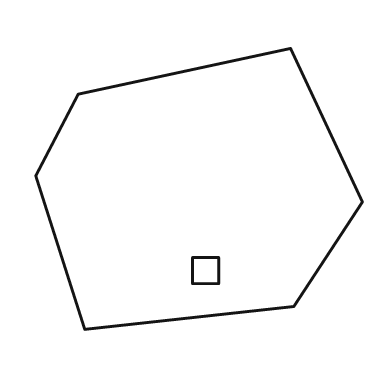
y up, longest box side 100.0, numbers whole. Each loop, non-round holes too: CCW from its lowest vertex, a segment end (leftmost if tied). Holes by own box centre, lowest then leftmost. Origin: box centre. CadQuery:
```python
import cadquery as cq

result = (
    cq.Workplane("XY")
    .moveTo(-35.0, -43.0)
    .lineTo(29.0, -36.0)
    .lineTo(50.0, -4.0)
    .lineTo(28.0, 43.0)
    .lineTo(-37.0, 29.0)
    .lineTo(-50.0, 4.0)
    .close()
    .moveTo(-2.0, -29.0)
    .lineTo(6.0, -29.0)
    .lineTo(6.0, -21.0)
    .lineTo(-2.0, -21.0)
    .close()
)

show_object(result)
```